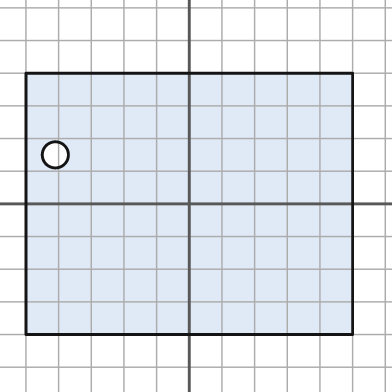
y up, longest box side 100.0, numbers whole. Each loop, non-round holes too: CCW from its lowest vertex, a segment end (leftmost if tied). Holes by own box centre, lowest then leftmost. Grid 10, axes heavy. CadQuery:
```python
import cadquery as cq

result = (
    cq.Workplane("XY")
    .moveTo(-50.0, -40.0)
    .lineTo(50.0, -40.0)
    .lineTo(50.0, 40.0)
    .lineTo(-50.0, 40.0)
    .close()
    .moveTo(-41.0, 15.0)
    .circle(4.0)
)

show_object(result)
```